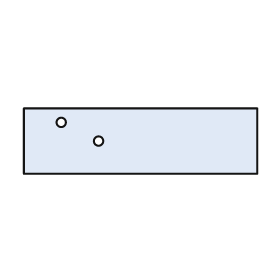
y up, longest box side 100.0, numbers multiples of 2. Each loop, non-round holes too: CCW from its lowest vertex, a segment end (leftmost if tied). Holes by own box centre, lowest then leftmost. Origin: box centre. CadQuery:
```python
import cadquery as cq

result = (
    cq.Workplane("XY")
    .moveTo(-50.0, -14.0)
    .lineTo(50.0, -14.0)
    .lineTo(50.0, 14.0)
    .lineTo(-50.0, 14.0)
    .close()
    .moveTo(-18.0, 0.0)
    .circle(2.0)
    .moveTo(-34.0, 8.0)
    .circle(2.0)
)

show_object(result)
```